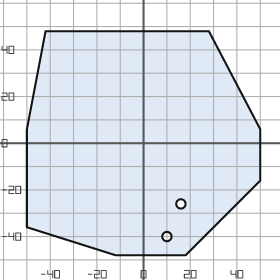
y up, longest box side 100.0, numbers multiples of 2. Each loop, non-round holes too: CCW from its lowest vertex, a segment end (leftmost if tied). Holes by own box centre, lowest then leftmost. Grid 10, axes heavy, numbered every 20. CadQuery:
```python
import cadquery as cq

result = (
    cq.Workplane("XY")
    .moveTo(-12.0, -48.0)
    .lineTo(18.0, -48.0)
    .lineTo(50.0, -16.0)
    .lineTo(50.0, 6.0)
    .lineTo(28.0, 48.0)
    .lineTo(-42.0, 48.0)
    .lineTo(-50.0, 6.0)
    .lineTo(-50.0, -36.0)
    .close()
    .moveTo(10.0, -40.0)
    .circle(2.0)
    .moveTo(16.0, -26.0)
    .circle(2.0)
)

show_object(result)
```